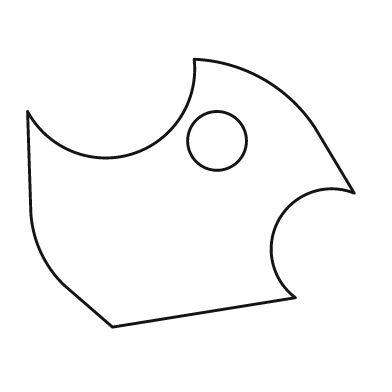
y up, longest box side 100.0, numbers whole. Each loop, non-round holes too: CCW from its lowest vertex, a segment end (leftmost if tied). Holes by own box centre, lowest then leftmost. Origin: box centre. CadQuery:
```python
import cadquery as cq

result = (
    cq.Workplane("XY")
    .moveTo(-24.0, -41.0)
    .lineTo(32.0, -32.0)
    .threePointArc((27.0, -8.0), (50.0, 0.0))
    .lineTo(38.0, 20.0)
    .threePointArc((22.0, 35.0), (1.0, 41.0))
    .threePointArc((-18.0, 12.0), (-50.0, 25.0))
    .lineTo(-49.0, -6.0)
    .threePointArc((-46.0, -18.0), (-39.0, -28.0))
    .close()
    .moveTo(8.0, 16.0)
    .circle(9.0)
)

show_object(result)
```